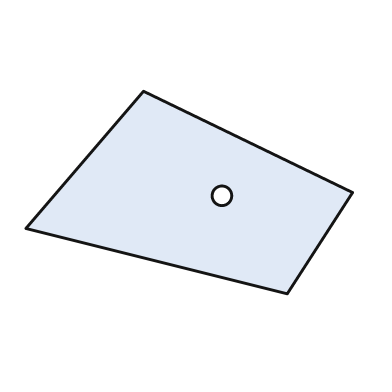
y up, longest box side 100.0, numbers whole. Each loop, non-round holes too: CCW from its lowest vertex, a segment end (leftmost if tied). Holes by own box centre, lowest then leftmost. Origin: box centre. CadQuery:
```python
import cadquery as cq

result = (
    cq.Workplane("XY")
    .moveTo(30.0, -31.0)
    .lineTo(50.0, 0.0)
    .lineTo(-14.0, 31.0)
    .lineTo(-50.0, -11.0)
    .close()
    .moveTo(10.0, -1.0)
    .circle(3.0)
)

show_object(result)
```